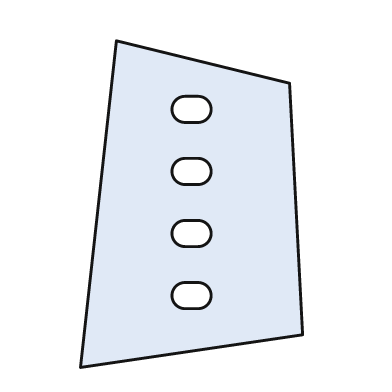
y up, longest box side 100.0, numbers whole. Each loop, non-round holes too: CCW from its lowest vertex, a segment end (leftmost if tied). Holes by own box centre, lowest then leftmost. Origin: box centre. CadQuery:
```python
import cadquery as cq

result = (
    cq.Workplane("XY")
    .moveTo(-34.0, -50.0)
    .lineTo(34.0, -40.0)
    .lineTo(30.0, 37.0)
    .lineTo(-23.0, 50.0)
    .close()
    .moveTo(-2.0, -32.0)
    .lineTo(2.0, -32.0)
    .threePointArc((6.0, -28.0), (2.0, -24.0))
    .lineTo(-2.0, -24.0)
    .threePointArc((-6.0, -28.0), (-2.0, -32.0))
    .close()
    .moveTo(-2.0, -13.0)
    .lineTo(2.0, -13.0)
    .threePointArc((6.0, -9.0), (2.0, -5.0))
    .lineTo(-2.0, -5.0)
    .threePointArc((-6.0, -9.0), (-2.0, -13.0))
    .close()
    .moveTo(-2.0, 6.0)
    .lineTo(2.0, 6.0)
    .threePointArc((6.0, 10.0), (2.0, 14.0))
    .lineTo(-2.0, 14.0)
    .threePointArc((-6.0, 10.0), (-2.0, 6.0))
    .close()
    .moveTo(-2.0, 25.0)
    .lineTo(2.0, 25.0)
    .threePointArc((6.0, 29.0), (2.0, 33.0))
    .lineTo(-2.0, 33.0)
    .threePointArc((-6.0, 29.0), (-2.0, 25.0))
    .close()
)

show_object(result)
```